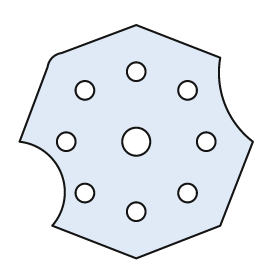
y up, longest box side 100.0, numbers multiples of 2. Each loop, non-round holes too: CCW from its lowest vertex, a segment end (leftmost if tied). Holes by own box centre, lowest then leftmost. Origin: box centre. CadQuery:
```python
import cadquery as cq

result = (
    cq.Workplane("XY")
    .moveTo(0.0, -50.0)
    .lineTo(36.0, -36.0)
    .lineTo(50.0, 0.0)
    .threePointArc((38.0, 16.0), (36.0, 36.0))
    .lineTo(0.0, 50.0)
    .lineTo(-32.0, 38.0)
    .threePointArc((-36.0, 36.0), (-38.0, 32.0))
    .lineTo(-50.0, 0.0)
    .threePointArc((-32.0, -14.0), (-36.0, -36.0))
    .close()
    .moveTo(0.0, -30.0)
    .circle(4.0)
    .moveTo(-22.0, -22.0)
    .circle(4.0)
    .moveTo(22.0, -22.0)
    .circle(4.0)
    .moveTo(-30.0, 0.0)
    .circle(4.0)
    .moveTo(0.0, 0.0)
    .circle(6.0)
    .moveTo(30.0, 0.0)
    .circle(4.0)
    .moveTo(-22.0, 22.0)
    .circle(4.0)
    .moveTo(22.0, 22.0)
    .circle(4.0)
    .moveTo(0.0, 30.0)
    .circle(4.0)
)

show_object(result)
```